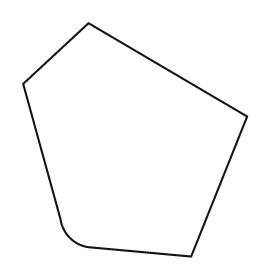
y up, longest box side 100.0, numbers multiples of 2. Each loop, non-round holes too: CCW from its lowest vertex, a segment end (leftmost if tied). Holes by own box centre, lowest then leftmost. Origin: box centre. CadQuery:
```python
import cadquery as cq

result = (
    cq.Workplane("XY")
    .moveTo(24.0, -50.0)
    .lineTo(48.0, 10.0)
    .lineTo(-20.0, 50.0)
    .lineTo(-48.0, 24.0)
    .lineTo(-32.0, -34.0)
    .threePointArc((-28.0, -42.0), (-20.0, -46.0))
    .close()
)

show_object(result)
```